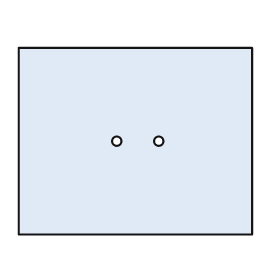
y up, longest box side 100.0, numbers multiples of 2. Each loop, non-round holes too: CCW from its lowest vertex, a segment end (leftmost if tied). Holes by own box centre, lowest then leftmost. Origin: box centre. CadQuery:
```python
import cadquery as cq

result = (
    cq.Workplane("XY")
    .moveTo(-50.0, -40.0)
    .lineTo(50.0, -40.0)
    .lineTo(50.0, 40.0)
    .lineTo(-50.0, 40.0)
    .close()
    .moveTo(-8.0, 0.0)
    .circle(2.0)
    .moveTo(10.0, 0.0)
    .circle(2.0)
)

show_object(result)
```